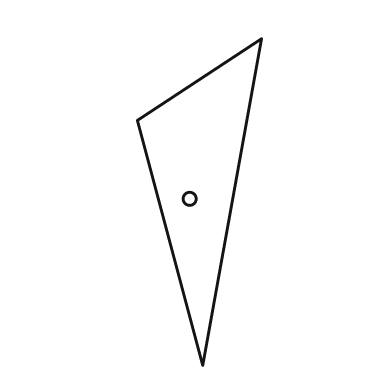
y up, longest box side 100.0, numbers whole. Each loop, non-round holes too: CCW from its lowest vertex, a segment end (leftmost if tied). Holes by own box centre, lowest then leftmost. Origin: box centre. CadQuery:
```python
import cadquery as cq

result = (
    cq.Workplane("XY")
    .moveTo(1.0, -50.0)
    .lineTo(19.0, 50.0)
    .lineTo(-19.0, 25.0)
    .close()
    .moveTo(-3.0, 1.0)
    .circle(2.0)
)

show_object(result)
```